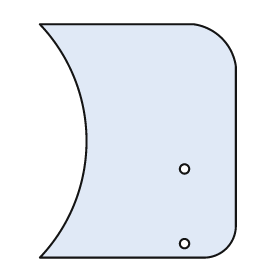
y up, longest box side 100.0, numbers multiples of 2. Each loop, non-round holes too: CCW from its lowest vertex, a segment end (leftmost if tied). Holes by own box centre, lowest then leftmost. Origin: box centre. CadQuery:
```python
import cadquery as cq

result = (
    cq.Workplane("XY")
    .moveTo(-42.0, -50.0)
    .lineTo(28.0, -50.0)
    .threePointArc((38.0, -46.0), (42.0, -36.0))
    .lineTo(42.0, 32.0)
    .threePointArc((36.0, 44.0), (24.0, 50.0))
    .lineTo(-42.0, 50.0)
    .threePointArc((-22.0, 0.0), (-42.0, -50.0))
    .close()
    .moveTo(20.0, -44.0)
    .circle(2.0)
    .moveTo(20.0, -12.0)
    .circle(2.0)
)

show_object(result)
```